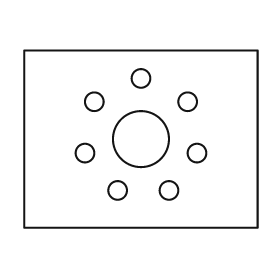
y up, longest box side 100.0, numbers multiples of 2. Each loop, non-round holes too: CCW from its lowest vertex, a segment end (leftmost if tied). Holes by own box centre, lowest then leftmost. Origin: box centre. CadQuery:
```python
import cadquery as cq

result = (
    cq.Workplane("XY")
    .moveTo(-50.0, -38.0)
    .lineTo(50.0, -38.0)
    .lineTo(50.0, 38.0)
    .lineTo(-50.0, 38.0)
    .close()
    .moveTo(-10.0, -22.0)
    .circle(4.0)
    .moveTo(12.0, -22.0)
    .circle(4.0)
    .moveTo(-24.0, -6.0)
    .circle(4.0)
    .moveTo(24.0, -6.0)
    .circle(4.0)
    .moveTo(0.0, 0.0)
    .circle(12.0)
    .moveTo(-20.0, 16.0)
    .circle(4.0)
    .moveTo(20.0, 16.0)
    .circle(4.0)
    .moveTo(0.0, 26.0)
    .circle(4.0)
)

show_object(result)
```